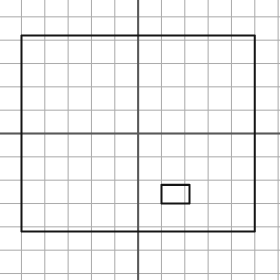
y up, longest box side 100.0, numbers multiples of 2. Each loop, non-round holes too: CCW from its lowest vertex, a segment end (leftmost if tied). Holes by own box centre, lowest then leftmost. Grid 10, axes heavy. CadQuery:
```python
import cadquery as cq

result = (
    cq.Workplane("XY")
    .moveTo(-50.0, -42.0)
    .lineTo(50.0, -42.0)
    .lineTo(50.0, 42.0)
    .lineTo(-50.0, 42.0)
    .close()
    .moveTo(10.0, -30.0)
    .lineTo(22.0, -30.0)
    .lineTo(22.0, -22.0)
    .lineTo(10.0, -22.0)
    .close()
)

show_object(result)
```